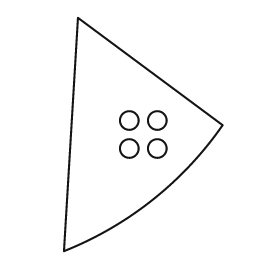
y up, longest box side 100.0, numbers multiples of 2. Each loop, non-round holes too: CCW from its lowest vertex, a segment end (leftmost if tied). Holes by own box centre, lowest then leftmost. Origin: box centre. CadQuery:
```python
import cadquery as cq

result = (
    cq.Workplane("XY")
    .moveTo(-34.0, -50.0)
    .threePointArc((4.0, -28.0), (34.0, 4.0))
    .lineTo(-28.0, 50.0)
    .close()
    .moveTo(-6.0, -6.0)
    .circle(4.0)
    .moveTo(6.0, -6.0)
    .circle(4.0)
    .moveTo(-6.0, 6.0)
    .circle(4.0)
    .moveTo(6.0, 6.0)
    .circle(4.0)
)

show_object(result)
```